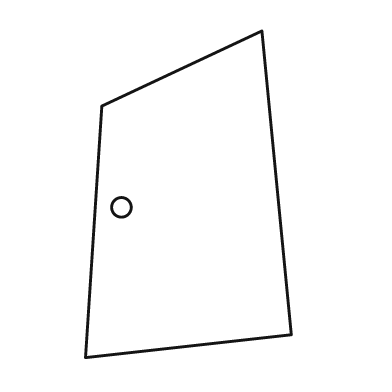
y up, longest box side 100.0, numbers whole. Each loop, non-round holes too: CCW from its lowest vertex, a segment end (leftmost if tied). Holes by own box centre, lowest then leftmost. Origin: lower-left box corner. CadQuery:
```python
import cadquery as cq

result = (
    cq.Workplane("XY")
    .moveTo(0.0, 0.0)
    .lineTo(63.0, 7.0)
    .lineTo(54.0, 100.0)
    .lineTo(5.0, 77.0)
    .close()
    .moveTo(11.0, 46.0)
    .circle(3.0)
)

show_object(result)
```